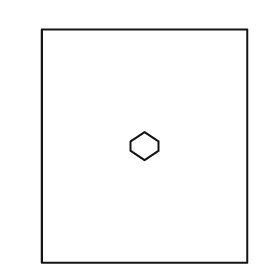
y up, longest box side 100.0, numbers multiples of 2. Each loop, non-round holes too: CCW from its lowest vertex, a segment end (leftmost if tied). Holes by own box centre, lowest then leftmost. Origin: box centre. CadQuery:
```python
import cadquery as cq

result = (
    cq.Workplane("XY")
    .moveTo(-44.0, -50.0)
    .lineTo(44.0, -50.0)
    .lineTo(44.0, 50.0)
    .lineTo(-44.0, 50.0)
    .close()
    .moveTo(0.0, -6.0)
    .lineTo(6.0, -2.0)
    .lineTo(6.0, 2.0)
    .lineTo(0.0, 6.0)
    .lineTo(-6.0, 2.0)
    .lineTo(-6.0, -2.0)
    .close()
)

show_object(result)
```